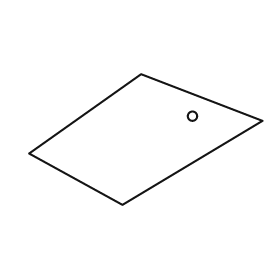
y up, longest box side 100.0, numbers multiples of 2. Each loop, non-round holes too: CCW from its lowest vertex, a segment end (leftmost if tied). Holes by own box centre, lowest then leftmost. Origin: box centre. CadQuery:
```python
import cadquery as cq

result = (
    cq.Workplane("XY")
    .moveTo(-10.0, -28.0)
    .lineTo(50.0, 8.0)
    .lineTo(-2.0, 28.0)
    .lineTo(-50.0, -6.0)
    .close()
    .moveTo(20.0, 10.0)
    .circle(2.0)
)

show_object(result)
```